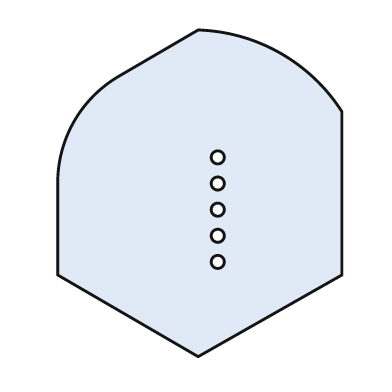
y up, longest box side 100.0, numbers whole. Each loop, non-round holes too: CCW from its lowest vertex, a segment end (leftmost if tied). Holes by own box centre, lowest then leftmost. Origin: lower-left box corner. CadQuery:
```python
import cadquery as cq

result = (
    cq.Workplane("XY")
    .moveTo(43.0, 0.0)
    .lineTo(87.0, 25.0)
    .lineTo(87.0, 75.0)
    .threePointArc((68.0, 93.0), (43.0, 100.0))
    .lineTo(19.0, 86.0)
    .threePointArc((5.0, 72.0), (0.0, 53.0))
    .lineTo(0.0, 25.0)
    .close()
    .moveTo(49.0, 29.0)
    .circle(2.0)
    .moveTo(49.0, 37.0)
    .circle(2.0)
    .moveTo(49.0, 45.0)
    .circle(2.0)
    .moveTo(49.0, 53.0)
    .circle(2.0)
    .moveTo(49.0, 61.0)
    .circle(2.0)
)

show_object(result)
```